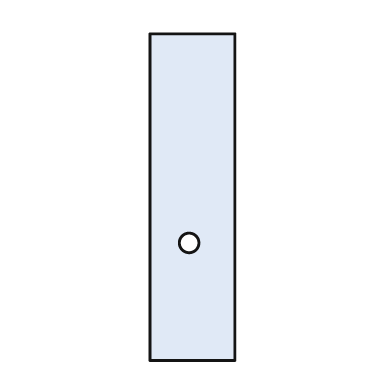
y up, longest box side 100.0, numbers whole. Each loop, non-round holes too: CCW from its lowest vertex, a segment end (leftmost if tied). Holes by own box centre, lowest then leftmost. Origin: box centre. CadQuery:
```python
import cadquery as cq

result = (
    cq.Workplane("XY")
    .moveTo(-13.0, -50.0)
    .lineTo(13.0, -50.0)
    .lineTo(13.0, 50.0)
    .lineTo(-13.0, 50.0)
    .close()
    .moveTo(-1.0, -14.0)
    .circle(3.0)
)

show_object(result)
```